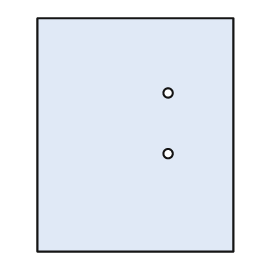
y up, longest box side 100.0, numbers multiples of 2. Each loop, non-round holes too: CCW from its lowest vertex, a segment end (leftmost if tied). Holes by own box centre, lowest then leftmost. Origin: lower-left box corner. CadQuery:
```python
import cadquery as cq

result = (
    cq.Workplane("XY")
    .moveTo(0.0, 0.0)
    .lineTo(84.0, 0.0)
    .lineTo(84.0, 100.0)
    .lineTo(0.0, 100.0)
    .close()
    .moveTo(56.0, 42.0)
    .circle(2.0)
    .moveTo(56.0, 68.0)
    .circle(2.0)
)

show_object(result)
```